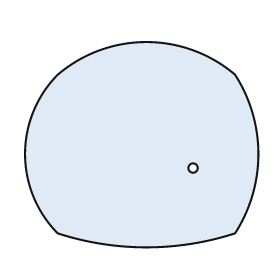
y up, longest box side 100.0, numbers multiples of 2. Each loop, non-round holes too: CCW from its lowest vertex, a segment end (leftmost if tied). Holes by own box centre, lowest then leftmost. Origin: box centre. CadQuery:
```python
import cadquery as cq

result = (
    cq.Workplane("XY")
    .moveTo(-36.0, -38.0)
    .threePointArc((2.0, -44.0), (40.0, -38.0))
    .threePointArc((50.0, -4.0), (40.0, 30.0))
    .threePointArc((2.0, 44.0), (-36.0, 30.0))
    .threePointArc((-50.0, -4.0), (-36.0, -38.0))
    .close()
    .moveTo(22.0, -10.0)
    .circle(2.0)
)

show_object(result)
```